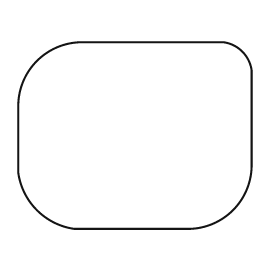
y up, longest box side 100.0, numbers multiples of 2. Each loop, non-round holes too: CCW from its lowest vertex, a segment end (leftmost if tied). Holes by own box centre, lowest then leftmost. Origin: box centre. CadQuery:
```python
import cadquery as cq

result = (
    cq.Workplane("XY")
    .moveTo(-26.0, -40.0)
    .lineTo(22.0, -40.0)
    .threePointArc((42.0, -32.0), (50.0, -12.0))
    .lineTo(50.0, 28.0)
    .threePointArc((46.0, 36.0), (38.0, 40.0))
    .lineTo(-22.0, 40.0)
    .threePointArc((-42.0, 32.0), (-50.0, 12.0))
    .lineTo(-50.0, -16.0)
    .threePointArc((-42.0, -32.0), (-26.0, -40.0))
    .close()
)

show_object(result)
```